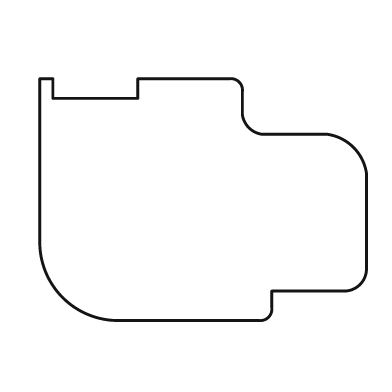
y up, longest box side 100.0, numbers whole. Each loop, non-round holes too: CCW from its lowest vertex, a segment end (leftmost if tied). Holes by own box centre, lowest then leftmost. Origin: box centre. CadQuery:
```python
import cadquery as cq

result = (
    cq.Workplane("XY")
    .moveTo(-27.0, -37.0)
    .lineTo(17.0, -37.0)
    .threePointArc((20.0, -36.0), (21.0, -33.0))
    .lineTo(21.0, -28.0)
    .lineTo(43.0, -28.0)
    .threePointArc((48.0, -26.0), (50.0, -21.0))
    .lineTo(50.0, 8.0)
    .threePointArc((46.0, 16.0), (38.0, 20.0))
    .lineTo(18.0, 20.0)
    .threePointArc((14.0, 22.0), (12.0, 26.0))
    .lineTo(12.0, 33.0)
    .threePointArc((11.0, 36.0), (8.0, 37.0))
    .lineTo(-20.0, 37.0)
    .lineTo(-20.0, 31.0)
    .lineTo(-46.0, 31.0)
    .lineTo(-46.0, 37.0)
    .lineTo(-50.0, 37.0)
    .lineTo(-50.0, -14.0)
    .threePointArc((-43.0, -30.0), (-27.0, -37.0))
    .close()
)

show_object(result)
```